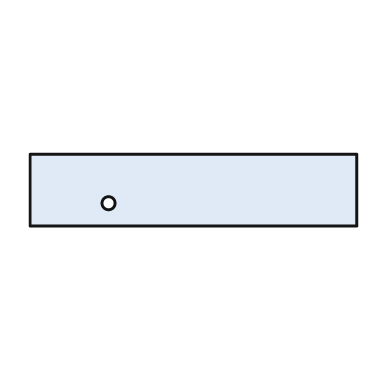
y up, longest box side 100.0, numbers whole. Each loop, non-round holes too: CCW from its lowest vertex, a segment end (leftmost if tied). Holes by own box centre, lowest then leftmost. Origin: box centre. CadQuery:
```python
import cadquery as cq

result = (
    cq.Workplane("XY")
    .moveTo(-50.0, -11.0)
    .lineTo(50.0, -11.0)
    .lineTo(50.0, 11.0)
    .lineTo(-50.0, 11.0)
    .close()
    .moveTo(-26.0, -4.0)
    .circle(2.0)
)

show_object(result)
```